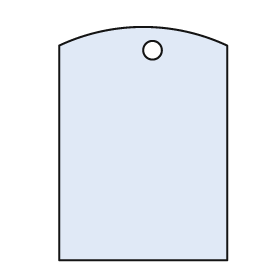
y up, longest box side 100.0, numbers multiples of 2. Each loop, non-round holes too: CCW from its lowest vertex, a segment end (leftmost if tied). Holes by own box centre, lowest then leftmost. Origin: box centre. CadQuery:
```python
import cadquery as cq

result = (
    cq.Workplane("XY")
    .moveTo(-36.0, -50.0)
    .lineTo(36.0, -50.0)
    .lineTo(36.0, 42.0)
    .threePointArc((0.0, 50.0), (-36.0, 42.0))
    .close()
    .moveTo(4.0, 40.0)
    .circle(4.0)
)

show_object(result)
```